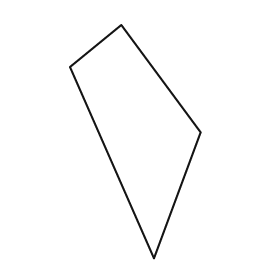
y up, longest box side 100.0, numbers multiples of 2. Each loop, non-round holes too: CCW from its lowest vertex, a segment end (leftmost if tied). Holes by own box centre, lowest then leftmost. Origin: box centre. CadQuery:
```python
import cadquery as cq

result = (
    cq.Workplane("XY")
    .moveTo(8.0, -50.0)
    .lineTo(28.0, 4.0)
    .lineTo(-6.0, 50.0)
    .lineTo(-28.0, 32.0)
    .close()
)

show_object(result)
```